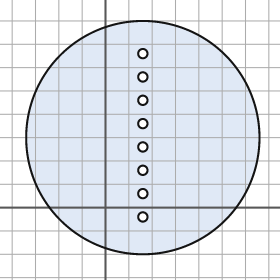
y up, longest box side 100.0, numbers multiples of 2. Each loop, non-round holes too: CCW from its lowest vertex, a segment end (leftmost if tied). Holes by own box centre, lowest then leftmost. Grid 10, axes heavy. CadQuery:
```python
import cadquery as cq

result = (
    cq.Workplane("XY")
    .moveTo(16.0, 30.0)
    .circle(50.0)
    .moveTo(16.0, -4.0)
    .circle(2.0)
    .moveTo(16.0, 6.0)
    .circle(2.0)
    .moveTo(16.0, 16.0)
    .circle(2.0)
    .moveTo(16.0, 26.0)
    .circle(2.0)
    .moveTo(16.0, 36.0)
    .circle(2.0)
    .moveTo(16.0, 46.0)
    .circle(2.0)
    .moveTo(16.0, 56.0)
    .circle(2.0)
    .moveTo(16.0, 66.0)
    .circle(2.0)
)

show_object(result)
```